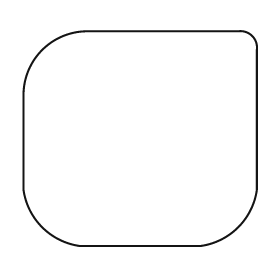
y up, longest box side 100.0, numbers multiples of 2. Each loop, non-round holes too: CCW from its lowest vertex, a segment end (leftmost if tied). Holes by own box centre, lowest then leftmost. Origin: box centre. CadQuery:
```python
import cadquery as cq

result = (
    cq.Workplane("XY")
    .moveTo(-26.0, -46.0)
    .lineTo(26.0, -46.0)
    .threePointArc((42.0, -38.0), (50.0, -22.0))
    .lineTo(50.0, 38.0)
    .threePointArc((48.0, 44.0), (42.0, 46.0))
    .lineTo(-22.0, 46.0)
    .threePointArc((-42.0, 38.0), (-50.0, 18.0))
    .lineTo(-50.0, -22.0)
    .threePointArc((-42.0, -38.0), (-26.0, -46.0))
    .close()
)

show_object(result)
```